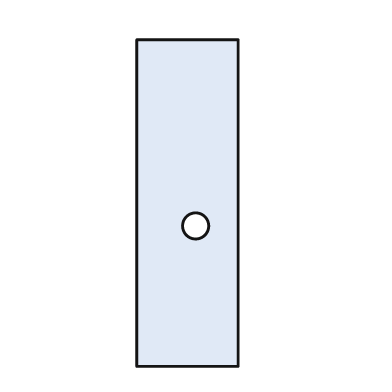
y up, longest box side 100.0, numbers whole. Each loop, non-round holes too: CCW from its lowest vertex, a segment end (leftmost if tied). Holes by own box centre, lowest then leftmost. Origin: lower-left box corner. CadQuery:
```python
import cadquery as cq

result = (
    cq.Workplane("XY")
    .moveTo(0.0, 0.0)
    .lineTo(31.0, 0.0)
    .lineTo(31.0, 100.0)
    .lineTo(0.0, 100.0)
    .close()
    .moveTo(18.0, 43.0)
    .circle(4.0)
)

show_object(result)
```